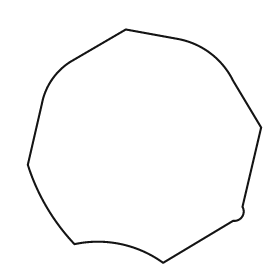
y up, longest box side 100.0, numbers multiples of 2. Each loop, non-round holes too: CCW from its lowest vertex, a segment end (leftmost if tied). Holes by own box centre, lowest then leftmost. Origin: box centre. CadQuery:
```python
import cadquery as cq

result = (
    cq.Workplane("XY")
    .moveTo(8.0, -50.0)
    .lineTo(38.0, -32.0)
    .threePointArc((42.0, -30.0), (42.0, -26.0))
    .lineTo(50.0, 8.0)
    .lineTo(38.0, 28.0)
    .threePointArc((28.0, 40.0), (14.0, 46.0))
    .lineTo(-8.0, 50.0)
    .lineTo(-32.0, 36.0)
    .threePointArc((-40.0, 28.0), (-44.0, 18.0))
    .lineTo(-50.0, -8.0)
    .threePointArc((-42.0, -26.0), (-30.0, -42.0))
    .threePointArc((-10.0, -42.0), (8.0, -50.0))
    .close()
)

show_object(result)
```